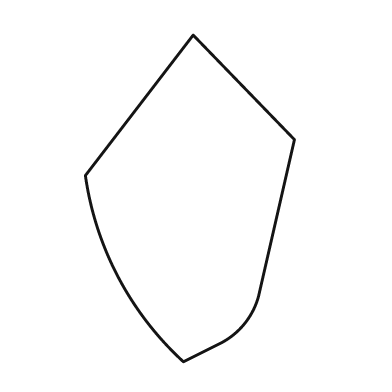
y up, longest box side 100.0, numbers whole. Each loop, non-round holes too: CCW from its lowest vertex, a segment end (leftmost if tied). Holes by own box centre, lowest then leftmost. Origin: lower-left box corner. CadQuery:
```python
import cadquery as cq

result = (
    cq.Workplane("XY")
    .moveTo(30.0, 0.0)
    .lineTo(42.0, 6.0)
    .threePointArc((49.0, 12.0), (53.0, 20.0))
    .lineTo(64.0, 68.0)
    .lineTo(33.0, 100.0)
    .lineTo(0.0, 57.0)
    .threePointArc((10.0, 26.0), (30.0, 0.0))
    .close()
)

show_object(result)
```